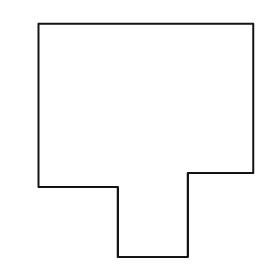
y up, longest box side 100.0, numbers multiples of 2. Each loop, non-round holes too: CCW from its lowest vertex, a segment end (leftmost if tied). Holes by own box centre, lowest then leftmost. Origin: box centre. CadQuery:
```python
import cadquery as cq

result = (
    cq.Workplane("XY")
    .moveTo(-12.0, -50.0)
    .lineTo(18.0, -50.0)
    .lineTo(18.0, -14.0)
    .lineTo(46.0, -14.0)
    .lineTo(46.0, 50.0)
    .lineTo(-46.0, 50.0)
    .lineTo(-46.0, -20.0)
    .lineTo(-12.0, -20.0)
    .close()
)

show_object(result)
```